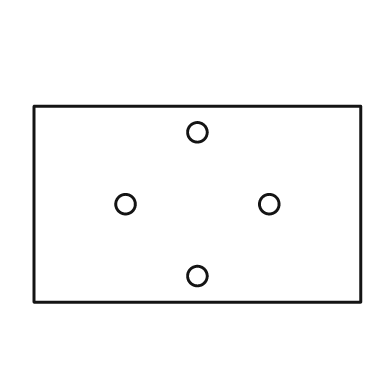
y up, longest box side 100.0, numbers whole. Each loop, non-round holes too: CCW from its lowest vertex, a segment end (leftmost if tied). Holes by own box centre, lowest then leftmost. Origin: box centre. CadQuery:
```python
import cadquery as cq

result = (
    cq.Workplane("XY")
    .moveTo(-50.0, -30.0)
    .lineTo(50.0, -30.0)
    .lineTo(50.0, 30.0)
    .lineTo(-50.0, 30.0)
    .close()
    .moveTo(0.0, -22.0)
    .circle(3.0)
    .moveTo(-22.0, 0.0)
    .circle(3.0)
    .moveTo(22.0, 0.0)
    .circle(3.0)
    .moveTo(0.0, 22.0)
    .circle(3.0)
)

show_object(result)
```